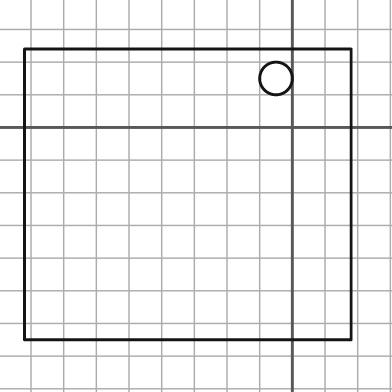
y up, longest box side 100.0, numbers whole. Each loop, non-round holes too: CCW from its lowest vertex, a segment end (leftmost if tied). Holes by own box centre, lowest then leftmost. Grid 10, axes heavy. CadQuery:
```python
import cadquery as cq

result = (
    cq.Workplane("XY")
    .moveTo(-82.0, -65.0)
    .lineTo(18.0, -65.0)
    .lineTo(18.0, 24.0)
    .lineTo(-82.0, 24.0)
    .close()
    .moveTo(-5.0, 15.0)
    .circle(5.0)
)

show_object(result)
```